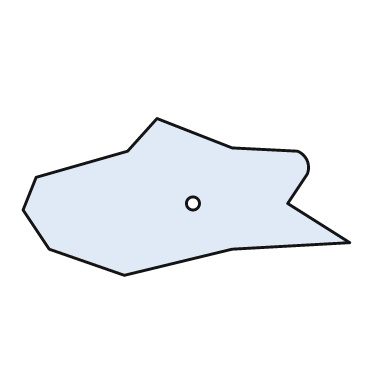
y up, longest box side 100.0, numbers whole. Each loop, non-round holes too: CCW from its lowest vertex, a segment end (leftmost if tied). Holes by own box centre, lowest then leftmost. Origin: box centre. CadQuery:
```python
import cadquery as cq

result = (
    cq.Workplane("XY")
    .moveTo(-19.0, -24.0)
    .lineTo(14.0, -16.0)
    .lineTo(50.0, -14.0)
    .lineTo(31.0, -2.0)
    .lineTo(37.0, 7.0)
    .threePointArc((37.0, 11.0), (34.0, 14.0))
    .lineTo(14.0, 15.0)
    .lineTo(-9.0, 24.0)
    .lineTo(-18.0, 14.0)
    .lineTo(-46.0, 6.0)
    .lineTo(-50.0, -4.0)
    .lineTo(-42.0, -16.0)
    .close()
    .moveTo(2.0, -2.0)
    .circle(2.0)
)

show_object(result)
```